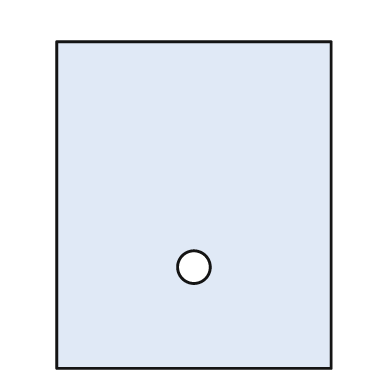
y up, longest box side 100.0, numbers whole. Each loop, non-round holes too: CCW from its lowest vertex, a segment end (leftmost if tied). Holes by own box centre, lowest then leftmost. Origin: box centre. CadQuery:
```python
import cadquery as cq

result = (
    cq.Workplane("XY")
    .moveTo(-42.0, -50.0)
    .lineTo(42.0, -50.0)
    .lineTo(42.0, 50.0)
    .lineTo(-42.0, 50.0)
    .close()
    .moveTo(0.0, -19.0)
    .circle(5.0)
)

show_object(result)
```